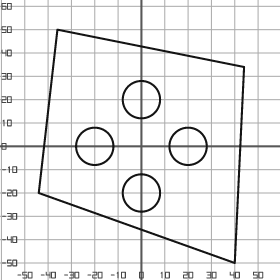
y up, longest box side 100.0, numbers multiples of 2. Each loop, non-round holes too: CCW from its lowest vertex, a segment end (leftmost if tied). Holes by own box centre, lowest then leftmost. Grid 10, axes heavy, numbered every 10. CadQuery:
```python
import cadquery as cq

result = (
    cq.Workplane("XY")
    .moveTo(40.0, -50.0)
    .lineTo(44.0, 34.0)
    .lineTo(-36.0, 50.0)
    .lineTo(-44.0, -20.0)
    .close()
    .moveTo(0.0, -20.0)
    .circle(8.0)
    .moveTo(-20.0, 0.0)
    .circle(8.0)
    .moveTo(20.0, 0.0)
    .circle(8.0)
    .moveTo(0.0, 20.0)
    .circle(8.0)
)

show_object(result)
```